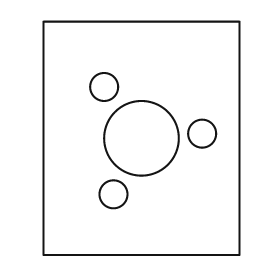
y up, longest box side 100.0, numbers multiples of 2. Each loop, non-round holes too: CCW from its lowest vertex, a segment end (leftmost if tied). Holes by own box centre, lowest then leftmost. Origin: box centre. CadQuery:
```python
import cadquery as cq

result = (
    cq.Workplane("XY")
    .moveTo(-42.0, -50.0)
    .lineTo(42.0, -50.0)
    .lineTo(42.0, 50.0)
    .lineTo(-42.0, 50.0)
    .close()
    .moveTo(-12.0, -24.0)
    .circle(6.0)
    .moveTo(0.0, 0.0)
    .circle(16.0)
    .moveTo(26.0, 2.0)
    .circle(6.0)
    .moveTo(-16.0, 22.0)
    .circle(6.0)
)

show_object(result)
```